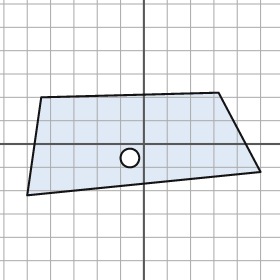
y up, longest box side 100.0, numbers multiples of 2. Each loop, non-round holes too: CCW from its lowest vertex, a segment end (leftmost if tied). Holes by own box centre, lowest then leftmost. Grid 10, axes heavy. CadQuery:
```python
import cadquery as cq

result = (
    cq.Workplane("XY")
    .moveTo(-50.0, -22.0)
    .lineTo(50.0, -12.0)
    .lineTo(32.0, 22.0)
    .lineTo(-44.0, 20.0)
    .close()
    .moveTo(-6.0, -6.0)
    .circle(4.0)
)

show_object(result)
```